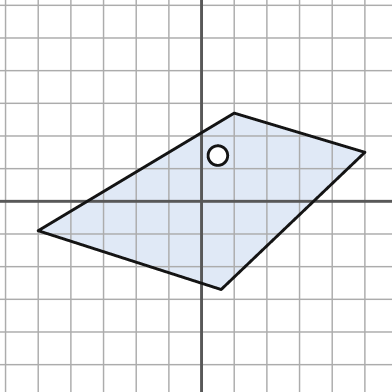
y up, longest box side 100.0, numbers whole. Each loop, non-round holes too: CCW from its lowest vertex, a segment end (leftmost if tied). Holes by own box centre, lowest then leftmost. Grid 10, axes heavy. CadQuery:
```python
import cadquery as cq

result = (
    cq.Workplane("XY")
    .moveTo(6.0, -27.0)
    .lineTo(50.0, 15.0)
    .lineTo(10.0, 27.0)
    .lineTo(-50.0, -9.0)
    .close()
    .moveTo(5.0, 14.0)
    .circle(3.0)
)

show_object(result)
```